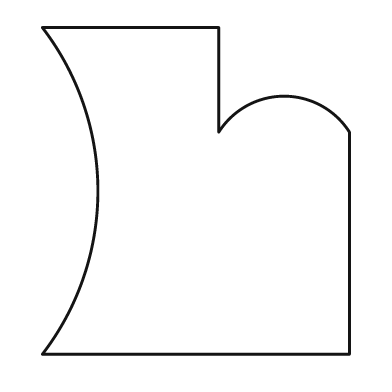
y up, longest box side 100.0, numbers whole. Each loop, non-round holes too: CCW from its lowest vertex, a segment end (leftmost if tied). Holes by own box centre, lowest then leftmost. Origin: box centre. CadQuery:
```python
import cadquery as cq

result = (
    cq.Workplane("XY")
    .moveTo(-47.0, -50.0)
    .lineTo(47.0, -50.0)
    .lineTo(47.0, 18.0)
    .threePointArc((27.0, 29.0), (7.0, 18.0))
    .lineTo(7.0, 50.0)
    .lineTo(-47.0, 50.0)
    .threePointArc((-30.0, 0.0), (-47.0, -50.0))
    .close()
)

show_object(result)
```